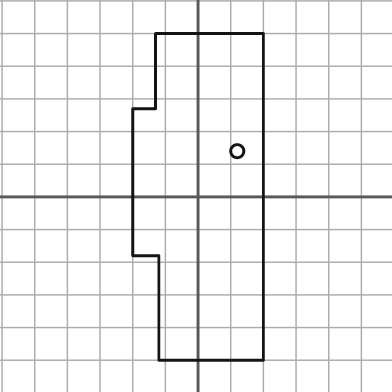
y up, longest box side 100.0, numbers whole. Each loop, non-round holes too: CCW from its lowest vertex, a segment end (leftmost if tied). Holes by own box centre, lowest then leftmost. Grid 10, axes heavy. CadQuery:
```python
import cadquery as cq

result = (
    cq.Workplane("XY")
    .moveTo(-12.0, -50.0)
    .lineTo(20.0, -50.0)
    .lineTo(20.0, 50.0)
    .lineTo(-13.0, 50.0)
    .lineTo(-13.0, 27.0)
    .lineTo(-20.0, 27.0)
    .lineTo(-20.0, -18.0)
    .lineTo(-12.0, -18.0)
    .close()
    .moveTo(12.0, 14.0)
    .circle(2.0)
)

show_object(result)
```